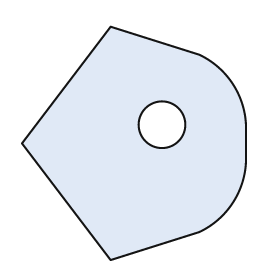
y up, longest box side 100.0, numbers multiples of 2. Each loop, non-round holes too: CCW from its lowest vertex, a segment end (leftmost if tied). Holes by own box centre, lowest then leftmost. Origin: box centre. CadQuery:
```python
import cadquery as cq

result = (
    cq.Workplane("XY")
    .moveTo(-10.0, -50.0)
    .lineTo(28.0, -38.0)
    .threePointArc((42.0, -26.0), (48.0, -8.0))
    .lineTo(48.0, 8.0)
    .threePointArc((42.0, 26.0), (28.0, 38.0))
    .lineTo(-10.0, 50.0)
    .lineTo(-48.0, 0.0)
    .close()
    .moveTo(12.0, 8.0)
    .circle(10.0)
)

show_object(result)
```